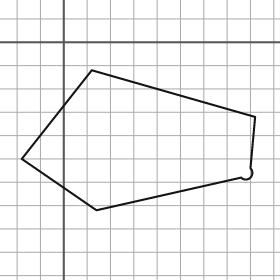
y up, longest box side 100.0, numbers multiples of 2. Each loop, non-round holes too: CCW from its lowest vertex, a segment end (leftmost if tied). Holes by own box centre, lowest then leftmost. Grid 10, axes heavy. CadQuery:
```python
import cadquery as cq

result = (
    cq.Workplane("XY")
    .moveTo(14.0, -72.0)
    .lineTo(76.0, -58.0)
    .threePointArc((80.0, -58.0), (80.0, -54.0))
    .lineTo(82.0, -32.0)
    .lineTo(12.0, -12.0)
    .lineTo(-18.0, -50.0)
    .close()
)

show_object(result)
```